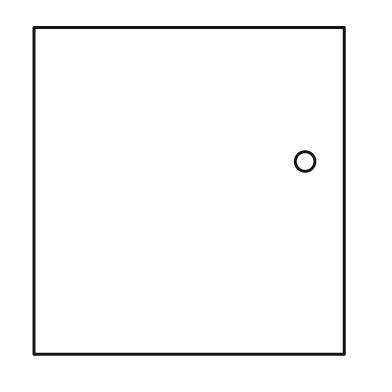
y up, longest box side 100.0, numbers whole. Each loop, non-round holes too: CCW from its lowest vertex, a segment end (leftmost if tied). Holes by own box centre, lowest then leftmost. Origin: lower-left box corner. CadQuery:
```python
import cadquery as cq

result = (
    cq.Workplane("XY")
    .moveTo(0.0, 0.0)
    .lineTo(95.0, 0.0)
    .lineTo(95.0, 100.0)
    .lineTo(0.0, 100.0)
    .close()
    .moveTo(83.0, 59.0)
    .circle(3.0)
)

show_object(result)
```